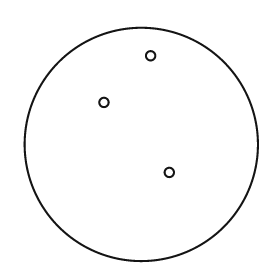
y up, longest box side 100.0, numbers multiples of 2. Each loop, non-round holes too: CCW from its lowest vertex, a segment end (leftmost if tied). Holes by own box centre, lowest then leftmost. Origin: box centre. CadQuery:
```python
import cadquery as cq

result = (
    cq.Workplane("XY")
    .moveTo(0.0, 0.0)
    .circle(50.0)
    .moveTo(12.0, -12.0)
    .circle(2.0)
    .moveTo(-16.0, 18.0)
    .circle(2.0)
    .moveTo(4.0, 38.0)
    .circle(2.0)
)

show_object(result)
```